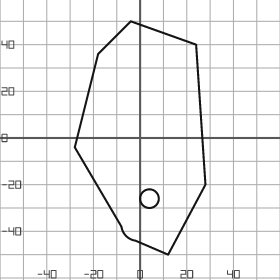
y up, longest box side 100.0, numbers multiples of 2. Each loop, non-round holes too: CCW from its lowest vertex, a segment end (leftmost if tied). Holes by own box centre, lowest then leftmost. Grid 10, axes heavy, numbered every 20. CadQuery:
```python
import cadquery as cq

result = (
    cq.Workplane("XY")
    .moveTo(12.0, -50.0)
    .lineTo(28.0, -20.0)
    .lineTo(24.0, 40.0)
    .lineTo(-4.0, 50.0)
    .lineTo(-18.0, 36.0)
    .lineTo(-28.0, -4.0)
    .lineTo(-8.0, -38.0)
    .threePointArc((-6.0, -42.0), (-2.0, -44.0))
    .close()
    .moveTo(4.0, -26.0)
    .circle(4.0)
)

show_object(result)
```